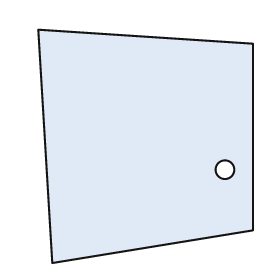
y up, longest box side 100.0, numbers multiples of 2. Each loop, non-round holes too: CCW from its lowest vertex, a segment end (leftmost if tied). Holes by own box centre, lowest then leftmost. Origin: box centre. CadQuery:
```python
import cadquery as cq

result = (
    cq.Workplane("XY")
    .moveTo(-40.0, -50.0)
    .lineTo(46.0, -36.0)
    .lineTo(46.0, 44.0)
    .lineTo(-46.0, 50.0)
    .close()
    .moveTo(34.0, -10.0)
    .circle(4.0)
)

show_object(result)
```